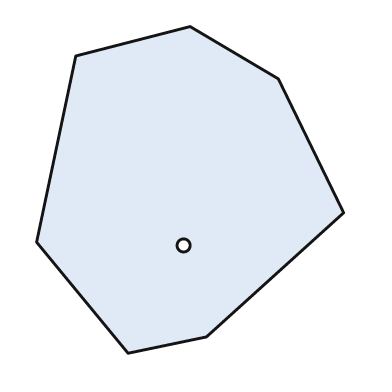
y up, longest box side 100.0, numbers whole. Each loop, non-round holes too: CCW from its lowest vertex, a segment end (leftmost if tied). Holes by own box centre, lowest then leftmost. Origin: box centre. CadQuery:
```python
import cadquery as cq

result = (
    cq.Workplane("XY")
    .moveTo(-19.0, -50.0)
    .lineTo(5.0, -45.0)
    .lineTo(47.0, -7.0)
    .lineTo(27.0, 34.0)
    .lineTo(0.0, 50.0)
    .lineTo(-35.0, 41.0)
    .lineTo(-47.0, -16.0)
    .close()
    .moveTo(-2.0, -17.0)
    .circle(2.0)
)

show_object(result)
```